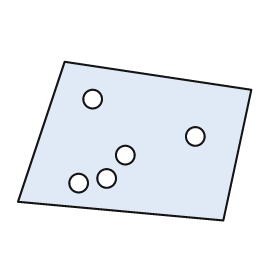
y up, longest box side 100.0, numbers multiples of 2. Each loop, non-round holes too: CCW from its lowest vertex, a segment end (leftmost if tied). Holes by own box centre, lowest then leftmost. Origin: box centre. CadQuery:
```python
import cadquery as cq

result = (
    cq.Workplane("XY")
    .moveTo(38.0, -34.0)
    .lineTo(50.0, 22.0)
    .lineTo(-30.0, 34.0)
    .lineTo(-50.0, -26.0)
    .close()
    .moveTo(-24.0, -18.0)
    .circle(4.0)
    .moveTo(-12.0, -16.0)
    .circle(4.0)
    .moveTo(-4.0, -6.0)
    .circle(4.0)
    .moveTo(26.0, 2.0)
    .circle(4.0)
    .moveTo(-18.0, 18.0)
    .circle(4.0)
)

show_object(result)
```